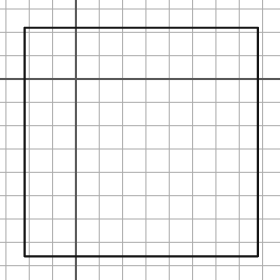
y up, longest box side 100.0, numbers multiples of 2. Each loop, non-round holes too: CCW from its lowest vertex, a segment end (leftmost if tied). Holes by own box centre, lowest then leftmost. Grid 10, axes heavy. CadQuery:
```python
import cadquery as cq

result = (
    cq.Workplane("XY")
    .moveTo(-22.0, -76.0)
    .lineTo(78.0, -76.0)
    .lineTo(78.0, 22.0)
    .lineTo(-22.0, 22.0)
    .close()
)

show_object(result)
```